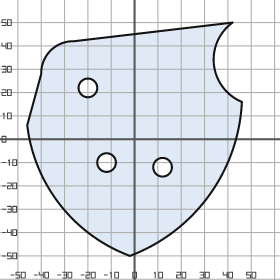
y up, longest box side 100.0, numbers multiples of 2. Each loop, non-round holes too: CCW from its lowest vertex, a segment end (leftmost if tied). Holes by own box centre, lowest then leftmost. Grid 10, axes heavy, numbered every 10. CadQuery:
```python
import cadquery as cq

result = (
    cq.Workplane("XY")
    .moveTo(-2.0, -50.0)
    .threePointArc((32.0, -24.0), (46.0, 16.0))
    .threePointArc((34.0, 32.0), (42.0, 50.0))
    .lineTo(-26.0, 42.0)
    .threePointArc((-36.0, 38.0), (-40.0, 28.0))
    .lineTo(-46.0, 6.0)
    .threePointArc((-32.0, -28.0), (-2.0, -50.0))
    .close()
    .moveTo(12.0, -12.0)
    .circle(4.0)
    .moveTo(-12.0, -10.0)
    .circle(4.0)
    .moveTo(-20.0, 22.0)
    .circle(4.0)
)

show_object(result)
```